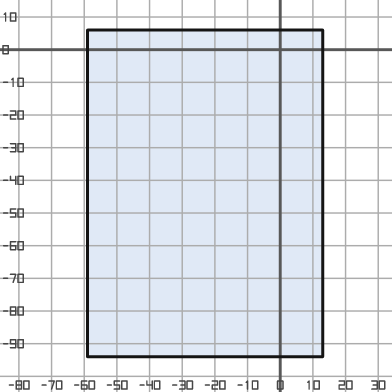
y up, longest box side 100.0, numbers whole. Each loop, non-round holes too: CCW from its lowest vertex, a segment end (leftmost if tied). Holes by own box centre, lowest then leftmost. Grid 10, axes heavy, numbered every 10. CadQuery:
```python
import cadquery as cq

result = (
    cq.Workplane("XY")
    .moveTo(-59.0, -94.0)
    .lineTo(13.0, -94.0)
    .lineTo(13.0, 6.0)
    .lineTo(-59.0, 6.0)
    .close()
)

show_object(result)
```